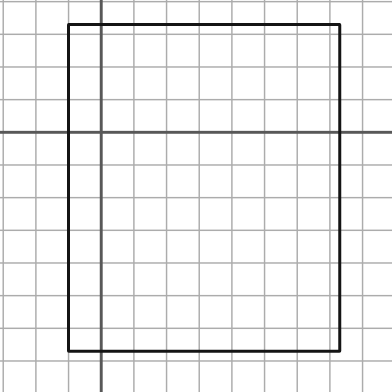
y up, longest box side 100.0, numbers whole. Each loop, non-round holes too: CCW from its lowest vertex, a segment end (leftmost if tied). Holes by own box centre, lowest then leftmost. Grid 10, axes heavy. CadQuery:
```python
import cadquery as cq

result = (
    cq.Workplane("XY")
    .moveTo(-10.0, -67.0)
    .lineTo(73.0, -67.0)
    .lineTo(73.0, 33.0)
    .lineTo(-10.0, 33.0)
    .close()
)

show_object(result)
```